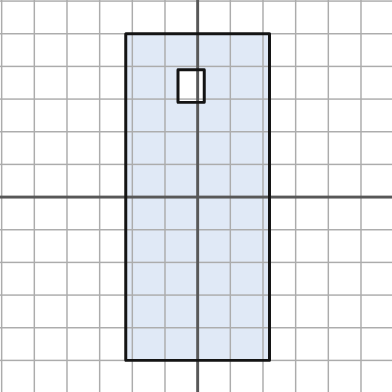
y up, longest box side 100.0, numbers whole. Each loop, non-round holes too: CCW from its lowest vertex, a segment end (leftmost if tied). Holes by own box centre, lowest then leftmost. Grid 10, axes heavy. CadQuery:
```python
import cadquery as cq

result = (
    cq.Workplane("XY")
    .moveTo(-22.0, -50.0)
    .lineTo(22.0, -50.0)
    .lineTo(22.0, 50.0)
    .lineTo(-22.0, 50.0)
    .close()
    .moveTo(-6.0, 29.0)
    .lineTo(2.0, 29.0)
    .lineTo(2.0, 39.0)
    .lineTo(-6.0, 39.0)
    .close()
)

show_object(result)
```